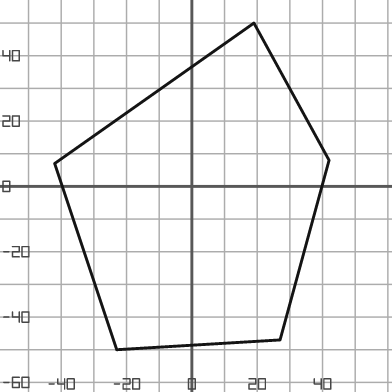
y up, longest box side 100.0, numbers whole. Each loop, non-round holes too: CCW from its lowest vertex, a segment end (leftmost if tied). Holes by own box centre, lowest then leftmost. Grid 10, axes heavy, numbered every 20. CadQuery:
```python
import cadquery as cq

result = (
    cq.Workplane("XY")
    .moveTo(-23.0, -50.0)
    .lineTo(27.0, -47.0)
    .lineTo(42.0, 8.0)
    .lineTo(19.0, 50.0)
    .lineTo(-42.0, 7.0)
    .close()
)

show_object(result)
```